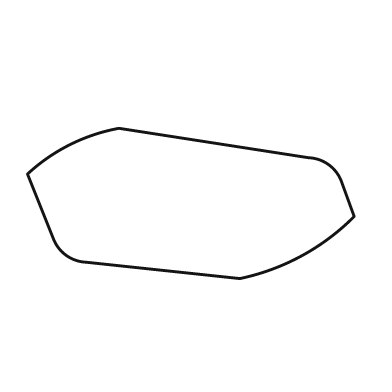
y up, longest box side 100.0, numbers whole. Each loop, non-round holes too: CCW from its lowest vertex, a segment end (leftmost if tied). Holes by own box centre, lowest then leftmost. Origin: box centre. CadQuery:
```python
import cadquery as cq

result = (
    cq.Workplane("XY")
    .moveTo(15.0, -23.0)
    .threePointArc((34.0, -16.0), (50.0, -4.0))
    .lineTo(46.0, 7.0)
    .threePointArc((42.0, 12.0), (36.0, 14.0))
    .lineTo(-22.0, 23.0)
    .threePointArc((-37.0, 18.0), (-50.0, 9.0))
    .lineTo(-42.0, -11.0)
    .threePointArc((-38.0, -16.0), (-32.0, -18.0))
    .close()
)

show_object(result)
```